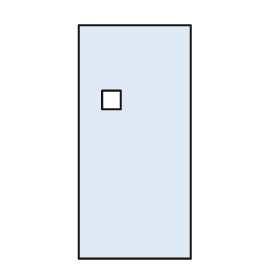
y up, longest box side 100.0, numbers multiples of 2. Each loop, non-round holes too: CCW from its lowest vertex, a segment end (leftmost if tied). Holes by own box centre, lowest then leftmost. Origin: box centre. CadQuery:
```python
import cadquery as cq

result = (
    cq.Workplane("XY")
    .moveTo(-24.0, -50.0)
    .lineTo(24.0, -50.0)
    .lineTo(24.0, 50.0)
    .lineTo(-24.0, 50.0)
    .close()
    .moveTo(-14.0, 14.0)
    .lineTo(-6.0, 14.0)
    .lineTo(-6.0, 22.0)
    .lineTo(-14.0, 22.0)
    .close()
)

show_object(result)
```